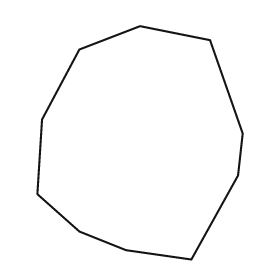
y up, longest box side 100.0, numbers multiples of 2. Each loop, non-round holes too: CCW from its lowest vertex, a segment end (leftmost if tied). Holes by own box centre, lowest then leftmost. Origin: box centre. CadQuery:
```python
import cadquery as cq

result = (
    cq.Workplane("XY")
    .moveTo(22.0, -50.0)
    .lineTo(42.0, -14.0)
    .lineTo(44.0, 4.0)
    .lineTo(30.0, 44.0)
    .lineTo(0.0, 50.0)
    .lineTo(-26.0, 40.0)
    .lineTo(-42.0, 10.0)
    .lineTo(-44.0, -22.0)
    .lineTo(-26.0, -38.0)
    .lineTo(-6.0, -46.0)
    .close()
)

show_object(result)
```